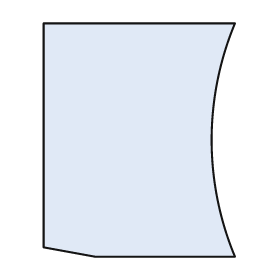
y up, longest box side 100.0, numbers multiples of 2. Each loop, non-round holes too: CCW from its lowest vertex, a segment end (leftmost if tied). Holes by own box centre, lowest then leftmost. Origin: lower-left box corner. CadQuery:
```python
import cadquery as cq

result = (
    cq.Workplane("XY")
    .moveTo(22.0, 0.0)
    .lineTo(82.0, 0.0)
    .threePointArc((72.0, 50.0), (82.0, 100.0))
    .lineTo(0.0, 100.0)
    .lineTo(0.0, 4.0)
    .close()
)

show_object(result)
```